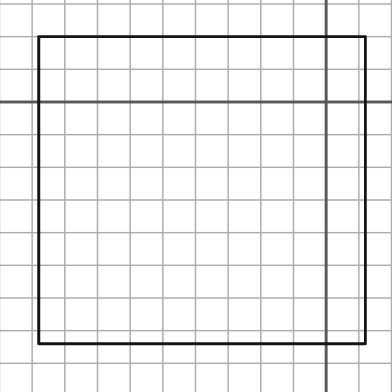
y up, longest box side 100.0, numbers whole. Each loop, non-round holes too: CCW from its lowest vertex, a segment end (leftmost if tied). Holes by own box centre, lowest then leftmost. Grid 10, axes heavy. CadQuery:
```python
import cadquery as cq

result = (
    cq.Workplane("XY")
    .moveTo(-88.0, -74.0)
    .lineTo(12.0, -74.0)
    .lineTo(12.0, 20.0)
    .lineTo(-88.0, 20.0)
    .close()
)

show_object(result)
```